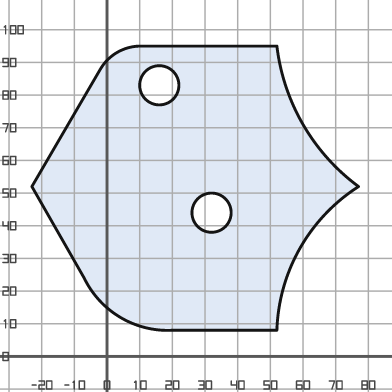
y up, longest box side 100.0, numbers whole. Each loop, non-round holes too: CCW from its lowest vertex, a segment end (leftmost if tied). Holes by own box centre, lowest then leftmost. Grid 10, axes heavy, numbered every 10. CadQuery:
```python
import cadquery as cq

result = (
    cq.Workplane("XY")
    .moveTo(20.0, 8.0)
    .lineTo(52.0, 8.0)
    .threePointArc((59.0, 33.0), (77.0, 52.0))
    .threePointArc((60.0, 71.0), (52.0, 95.0))
    .lineTo(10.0, 95.0)
    .threePointArc((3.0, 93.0), (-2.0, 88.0))
    .lineTo(-23.0, 52.0)
    .lineTo(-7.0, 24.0)
    .threePointArc((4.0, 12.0), (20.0, 8.0))
    .close()
    .moveTo(32.0, 44.0)
    .circle(6.0)
    .moveTo(16.0, 83.0)
    .circle(6.0)
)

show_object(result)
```